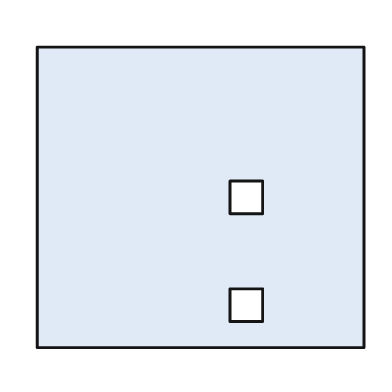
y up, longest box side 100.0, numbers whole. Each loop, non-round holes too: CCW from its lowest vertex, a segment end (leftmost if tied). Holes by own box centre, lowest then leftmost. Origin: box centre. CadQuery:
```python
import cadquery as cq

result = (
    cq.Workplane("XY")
    .moveTo(-50.0, -46.0)
    .lineTo(50.0, -46.0)
    .lineTo(50.0, 46.0)
    .lineTo(-50.0, 46.0)
    .close()
    .moveTo(9.0, -38.0)
    .lineTo(19.0, -38.0)
    .lineTo(19.0, -28.0)
    .lineTo(9.0, -28.0)
    .close()
    .moveTo(9.0, -5.0)
    .lineTo(19.0, -5.0)
    .lineTo(19.0, 5.0)
    .lineTo(9.0, 5.0)
    .close()
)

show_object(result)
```